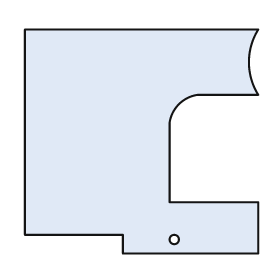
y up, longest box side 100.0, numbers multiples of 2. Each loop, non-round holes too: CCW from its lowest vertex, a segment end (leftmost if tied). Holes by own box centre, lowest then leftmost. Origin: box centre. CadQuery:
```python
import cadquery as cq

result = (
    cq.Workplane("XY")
    .moveTo(-8.0, -48.0)
    .lineTo(50.0, -48.0)
    .lineTo(50.0, -26.0)
    .lineTo(12.0, -26.0)
    .lineTo(12.0, 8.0)
    .threePointArc((16.0, 16.0), (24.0, 20.0))
    .lineTo(50.0, 20.0)
    .threePointArc((46.0, 34.0), (50.0, 48.0))
    .lineTo(-50.0, 48.0)
    .lineTo(-50.0, -40.0)
    .lineTo(-8.0, -40.0)
    .close()
    .moveTo(14.0, -42.0)
    .circle(2.0)
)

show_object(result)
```